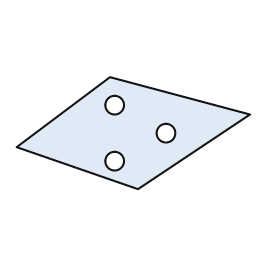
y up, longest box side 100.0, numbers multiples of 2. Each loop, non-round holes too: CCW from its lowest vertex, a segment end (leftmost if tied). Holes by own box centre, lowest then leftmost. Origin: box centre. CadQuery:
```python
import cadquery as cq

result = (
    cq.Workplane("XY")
    .moveTo(2.0, -24.0)
    .lineTo(50.0, 8.0)
    .lineTo(-10.0, 24.0)
    .lineTo(-50.0, -6.0)
    .close()
    .moveTo(-8.0, -12.0)
    .circle(4.0)
    .moveTo(14.0, 0.0)
    .circle(4.0)
    .moveTo(-8.0, 12.0)
    .circle(4.0)
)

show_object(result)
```